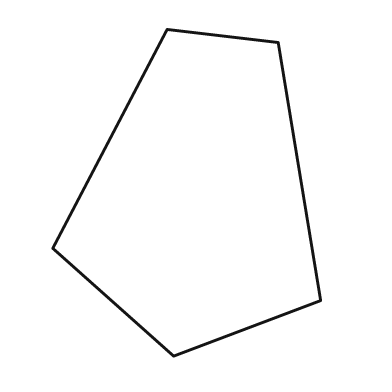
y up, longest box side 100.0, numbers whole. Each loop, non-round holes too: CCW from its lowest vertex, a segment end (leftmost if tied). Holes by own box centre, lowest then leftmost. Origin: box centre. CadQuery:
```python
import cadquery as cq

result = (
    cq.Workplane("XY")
    .moveTo(-4.0, -50.0)
    .lineTo(41.0, -33.0)
    .lineTo(28.0, 46.0)
    .lineTo(-6.0, 50.0)
    .lineTo(-41.0, -17.0)
    .close()
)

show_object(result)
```